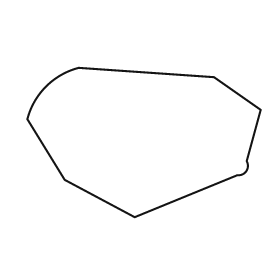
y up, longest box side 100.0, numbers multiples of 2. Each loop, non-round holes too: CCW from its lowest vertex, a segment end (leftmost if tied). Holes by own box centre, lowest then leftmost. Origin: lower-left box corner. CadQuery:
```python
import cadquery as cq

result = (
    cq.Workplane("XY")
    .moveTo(46.0, 0.0)
    .lineTo(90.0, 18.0)
    .threePointArc((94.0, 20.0), (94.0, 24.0))
    .lineTo(100.0, 46.0)
    .lineTo(80.0, 60.0)
    .lineTo(22.0, 64.0)
    .threePointArc((8.0, 56.0), (0.0, 42.0))
    .lineTo(16.0, 16.0)
    .close()
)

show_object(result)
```